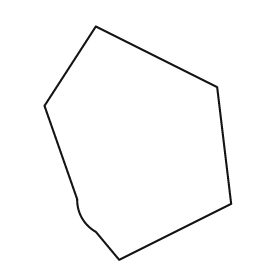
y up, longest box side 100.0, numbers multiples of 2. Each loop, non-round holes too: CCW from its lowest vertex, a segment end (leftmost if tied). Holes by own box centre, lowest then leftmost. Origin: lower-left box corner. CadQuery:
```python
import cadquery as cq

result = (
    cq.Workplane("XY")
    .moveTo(32.0, 0.0)
    .lineTo(80.0, 24.0)
    .lineTo(74.0, 74.0)
    .lineTo(22.0, 100.0)
    .lineTo(0.0, 66.0)
    .lineTo(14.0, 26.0)
    .threePointArc((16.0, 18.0), (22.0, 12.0))
    .close()
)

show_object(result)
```